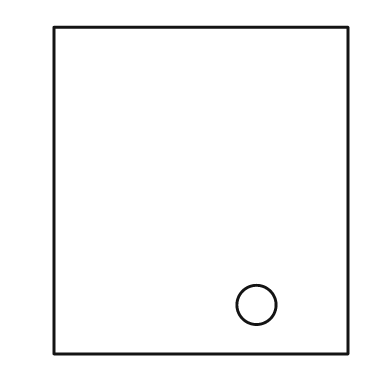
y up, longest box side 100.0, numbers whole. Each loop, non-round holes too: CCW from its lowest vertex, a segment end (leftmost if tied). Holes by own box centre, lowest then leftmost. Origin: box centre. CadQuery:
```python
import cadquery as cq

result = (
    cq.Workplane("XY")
    .moveTo(-45.0, -50.0)
    .lineTo(45.0, -50.0)
    .lineTo(45.0, 50.0)
    .lineTo(-45.0, 50.0)
    .close()
    .moveTo(17.0, -35.0)
    .circle(6.0)
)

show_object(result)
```